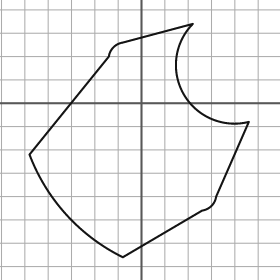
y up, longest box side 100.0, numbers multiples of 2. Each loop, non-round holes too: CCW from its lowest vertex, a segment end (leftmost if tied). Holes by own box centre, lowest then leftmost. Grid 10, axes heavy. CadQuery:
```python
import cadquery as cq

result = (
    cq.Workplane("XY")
    .moveTo(-8.0, -66.0)
    .lineTo(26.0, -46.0)
    .threePointArc((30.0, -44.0), (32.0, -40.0))
    .lineTo(46.0, -8.0)
    .threePointArc((18.0, 4.0), (22.0, 34.0))
    .lineTo(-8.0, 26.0)
    .threePointArc((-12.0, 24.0), (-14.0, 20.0))
    .lineTo(-48.0, -22.0)
    .threePointArc((-32.0, -48.0), (-8.0, -66.0))
    .close()
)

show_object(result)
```